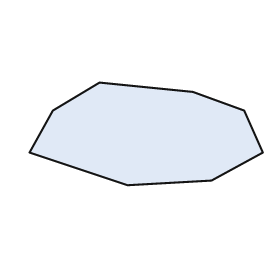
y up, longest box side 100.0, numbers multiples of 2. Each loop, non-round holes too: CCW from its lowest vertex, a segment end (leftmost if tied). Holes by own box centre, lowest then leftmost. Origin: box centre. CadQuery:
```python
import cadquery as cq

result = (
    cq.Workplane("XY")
    .moveTo(-8.0, -22.0)
    .lineTo(28.0, -20.0)
    .lineTo(50.0, -8.0)
    .lineTo(42.0, 10.0)
    .lineTo(20.0, 18.0)
    .lineTo(-20.0, 22.0)
    .lineTo(-40.0, 10.0)
    .lineTo(-50.0, -8.0)
    .close()
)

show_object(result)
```